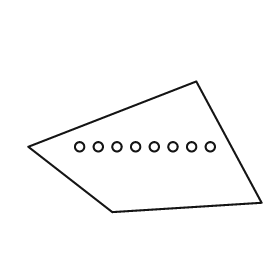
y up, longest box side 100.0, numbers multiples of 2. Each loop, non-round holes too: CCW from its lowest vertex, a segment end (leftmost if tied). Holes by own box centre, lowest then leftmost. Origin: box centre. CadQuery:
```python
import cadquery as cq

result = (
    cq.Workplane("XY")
    .moveTo(-14.0, -28.0)
    .lineTo(50.0, -24.0)
    .lineTo(22.0, 28.0)
    .lineTo(-50.0, 0.0)
    .close()
    .moveTo(-28.0, 0.0)
    .circle(2.0)
    .moveTo(-20.0, 0.0)
    .circle(2.0)
    .moveTo(-12.0, 0.0)
    .circle(2.0)
    .moveTo(-4.0, 0.0)
    .circle(2.0)
    .moveTo(4.0, 0.0)
    .circle(2.0)
    .moveTo(12.0, 0.0)
    .circle(2.0)
    .moveTo(20.0, 0.0)
    .circle(2.0)
    .moveTo(28.0, 0.0)
    .circle(2.0)
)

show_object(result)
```